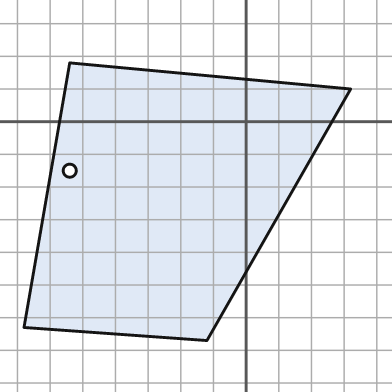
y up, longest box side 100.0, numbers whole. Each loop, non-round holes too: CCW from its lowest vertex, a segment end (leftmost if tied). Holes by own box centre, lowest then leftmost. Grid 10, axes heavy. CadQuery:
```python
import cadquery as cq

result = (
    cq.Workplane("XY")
    .moveTo(-12.0, -67.0)
    .lineTo(32.0, 10.0)
    .lineTo(-54.0, 18.0)
    .lineTo(-68.0, -63.0)
    .close()
    .moveTo(-54.0, -15.0)
    .circle(2.0)
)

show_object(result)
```